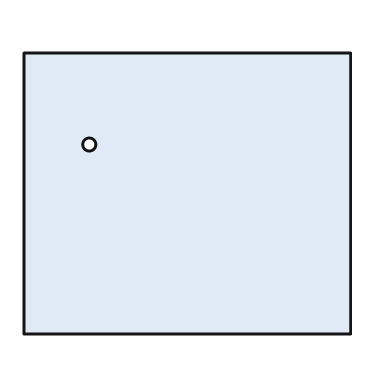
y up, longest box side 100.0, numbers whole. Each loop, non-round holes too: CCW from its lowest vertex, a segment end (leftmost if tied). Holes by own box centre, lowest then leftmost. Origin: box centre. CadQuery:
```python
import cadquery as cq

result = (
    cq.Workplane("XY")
    .moveTo(-50.0, -43.0)
    .lineTo(50.0, -43.0)
    .lineTo(50.0, 43.0)
    .lineTo(-50.0, 43.0)
    .close()
    .moveTo(-30.0, 15.0)
    .circle(2.0)
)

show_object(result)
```